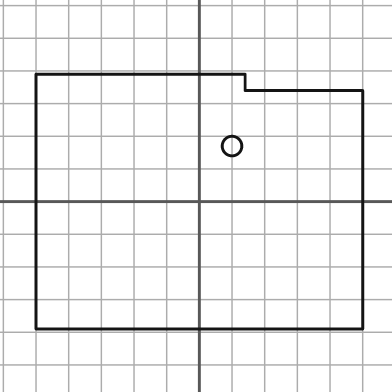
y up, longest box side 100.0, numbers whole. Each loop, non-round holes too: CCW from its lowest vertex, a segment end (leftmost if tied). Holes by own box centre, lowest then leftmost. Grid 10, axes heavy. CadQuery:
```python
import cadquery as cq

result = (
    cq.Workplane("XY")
    .moveTo(-50.0, -39.0)
    .lineTo(50.0, -39.0)
    .lineTo(50.0, 34.0)
    .lineTo(14.0, 34.0)
    .lineTo(14.0, 39.0)
    .lineTo(-50.0, 39.0)
    .close()
    .moveTo(10.0, 17.0)
    .circle(3.0)
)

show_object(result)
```